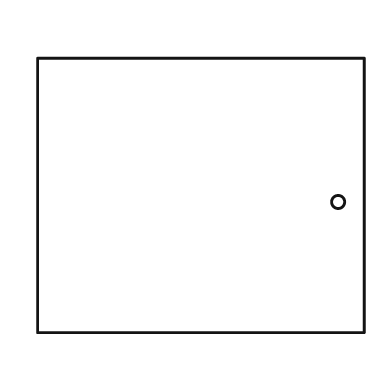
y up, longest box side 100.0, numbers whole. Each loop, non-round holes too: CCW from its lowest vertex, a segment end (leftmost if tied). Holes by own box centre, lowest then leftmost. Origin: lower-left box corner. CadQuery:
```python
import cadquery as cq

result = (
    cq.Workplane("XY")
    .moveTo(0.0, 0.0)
    .lineTo(100.0, 0.0)
    .lineTo(100.0, 84.0)
    .lineTo(0.0, 84.0)
    .close()
    .moveTo(92.0, 40.0)
    .circle(2.0)
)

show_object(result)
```